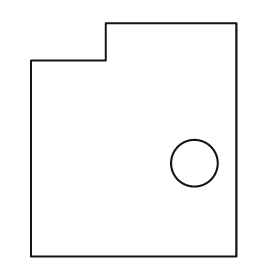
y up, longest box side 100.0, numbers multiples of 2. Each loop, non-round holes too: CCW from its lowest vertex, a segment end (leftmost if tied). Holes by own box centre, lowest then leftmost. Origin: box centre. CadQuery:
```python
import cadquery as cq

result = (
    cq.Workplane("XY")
    .moveTo(-44.0, -50.0)
    .lineTo(44.0, -50.0)
    .lineTo(44.0, 50.0)
    .lineTo(-12.0, 50.0)
    .lineTo(-12.0, 34.0)
    .lineTo(-44.0, 34.0)
    .close()
    .moveTo(26.0, -10.0)
    .circle(10.0)
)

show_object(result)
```